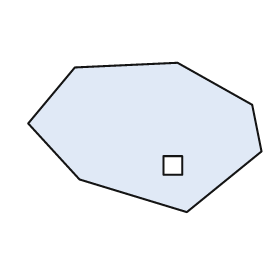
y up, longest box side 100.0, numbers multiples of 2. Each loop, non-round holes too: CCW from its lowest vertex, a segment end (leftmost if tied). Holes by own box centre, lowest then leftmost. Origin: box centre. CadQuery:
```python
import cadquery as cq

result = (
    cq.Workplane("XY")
    .moveTo(18.0, -32.0)
    .lineTo(50.0, -6.0)
    .lineTo(46.0, 14.0)
    .lineTo(14.0, 32.0)
    .lineTo(-30.0, 30.0)
    .lineTo(-50.0, 6.0)
    .lineTo(-28.0, -18.0)
    .close()
    .moveTo(8.0, -16.0)
    .lineTo(16.0, -16.0)
    .lineTo(16.0, -8.0)
    .lineTo(8.0, -8.0)
    .close()
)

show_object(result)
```